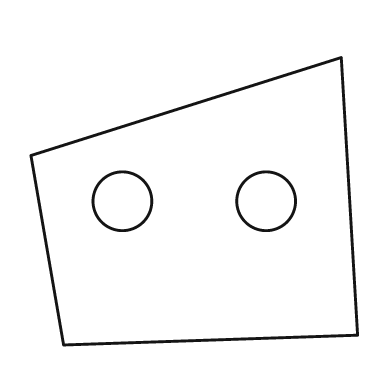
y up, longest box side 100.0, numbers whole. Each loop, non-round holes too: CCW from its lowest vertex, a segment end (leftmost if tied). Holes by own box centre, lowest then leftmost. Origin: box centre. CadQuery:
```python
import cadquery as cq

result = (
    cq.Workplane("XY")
    .moveTo(-40.0, -44.0)
    .lineTo(50.0, -41.0)
    .lineTo(45.0, 44.0)
    .lineTo(-50.0, 14.0)
    .close()
    .moveTo(-22.0, 0.0)
    .circle(9.0)
    .moveTo(22.0, 0.0)
    .circle(9.0)
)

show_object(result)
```